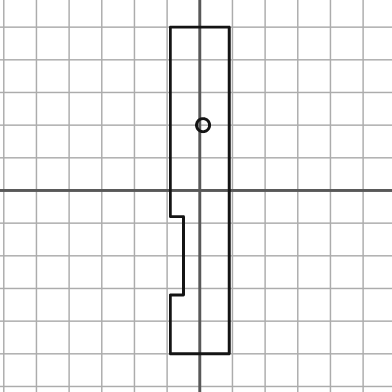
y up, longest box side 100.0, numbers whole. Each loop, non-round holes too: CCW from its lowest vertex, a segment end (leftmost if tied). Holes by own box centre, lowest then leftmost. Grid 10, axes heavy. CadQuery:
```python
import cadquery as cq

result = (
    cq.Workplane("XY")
    .moveTo(-9.0, -50.0)
    .lineTo(9.0, -50.0)
    .lineTo(9.0, 50.0)
    .lineTo(-9.0, 50.0)
    .lineTo(-9.0, -8.0)
    .lineTo(-5.0, -8.0)
    .lineTo(-5.0, -32.0)
    .lineTo(-9.0, -32.0)
    .close()
    .moveTo(1.0, 20.0)
    .circle(2.0)
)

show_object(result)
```